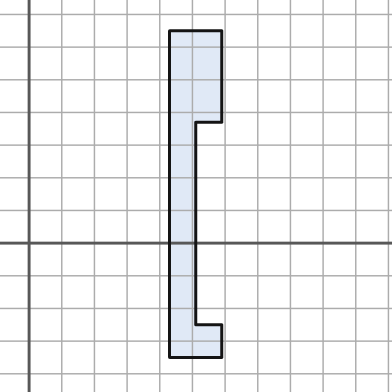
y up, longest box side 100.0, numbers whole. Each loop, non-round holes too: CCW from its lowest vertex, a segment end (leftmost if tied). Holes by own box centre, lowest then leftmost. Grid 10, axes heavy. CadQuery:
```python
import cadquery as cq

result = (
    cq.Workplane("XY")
    .moveTo(43.0, -35.0)
    .lineTo(59.0, -35.0)
    .lineTo(59.0, -25.0)
    .lineTo(51.0, -25.0)
    .lineTo(51.0, 37.0)
    .lineTo(59.0, 37.0)
    .lineTo(59.0, 65.0)
    .lineTo(43.0, 65.0)
    .close()
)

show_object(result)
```